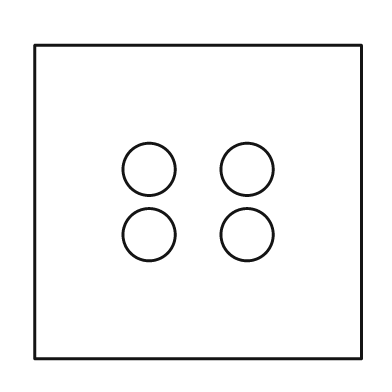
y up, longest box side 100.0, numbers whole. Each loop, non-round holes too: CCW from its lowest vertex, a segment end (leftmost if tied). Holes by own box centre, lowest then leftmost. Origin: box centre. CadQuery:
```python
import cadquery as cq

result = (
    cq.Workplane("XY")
    .moveTo(-50.0, -48.0)
    .lineTo(50.0, -48.0)
    .lineTo(50.0, 48.0)
    .lineTo(-50.0, 48.0)
    .close()
    .moveTo(-15.0, -10.0)
    .circle(8.0)
    .moveTo(15.0, -10.0)
    .circle(8.0)
    .moveTo(-15.0, 10.0)
    .circle(8.0)
    .moveTo(15.0, 10.0)
    .circle(8.0)
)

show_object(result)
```